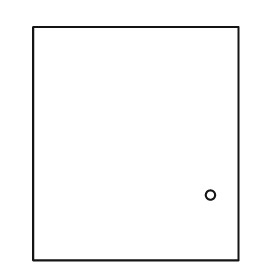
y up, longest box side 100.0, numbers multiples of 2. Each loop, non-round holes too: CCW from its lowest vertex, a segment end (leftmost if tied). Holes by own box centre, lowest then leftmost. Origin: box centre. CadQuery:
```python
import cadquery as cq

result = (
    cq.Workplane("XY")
    .moveTo(-44.0, -50.0)
    .lineTo(44.0, -50.0)
    .lineTo(44.0, 50.0)
    .lineTo(-44.0, 50.0)
    .close()
    .moveTo(32.0, -22.0)
    .circle(2.0)
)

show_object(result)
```